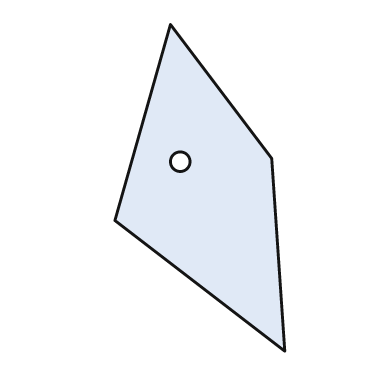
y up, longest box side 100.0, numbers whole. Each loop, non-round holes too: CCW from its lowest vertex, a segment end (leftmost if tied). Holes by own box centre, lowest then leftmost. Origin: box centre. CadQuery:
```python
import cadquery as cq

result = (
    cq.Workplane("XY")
    .moveTo(26.0, -50.0)
    .lineTo(22.0, 9.0)
    .lineTo(-9.0, 50.0)
    .lineTo(-26.0, -10.0)
    .close()
    .moveTo(-6.0, 8.0)
    .circle(3.0)
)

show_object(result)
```